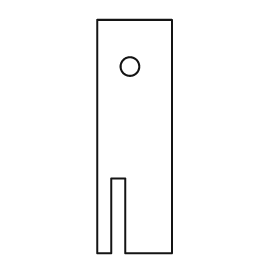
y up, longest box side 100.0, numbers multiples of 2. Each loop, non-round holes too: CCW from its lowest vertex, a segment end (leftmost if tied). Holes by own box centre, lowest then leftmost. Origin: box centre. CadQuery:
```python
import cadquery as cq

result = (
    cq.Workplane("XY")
    .moveTo(-16.0, -50.0)
    .lineTo(-10.0, -50.0)
    .lineTo(-10.0, -18.0)
    .lineTo(-4.0, -18.0)
    .lineTo(-4.0, -50.0)
    .lineTo(16.0, -50.0)
    .lineTo(16.0, 50.0)
    .lineTo(-16.0, 50.0)
    .close()
    .moveTo(-2.0, 30.0)
    .circle(4.0)
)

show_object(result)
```